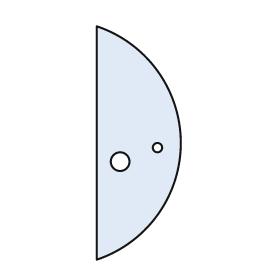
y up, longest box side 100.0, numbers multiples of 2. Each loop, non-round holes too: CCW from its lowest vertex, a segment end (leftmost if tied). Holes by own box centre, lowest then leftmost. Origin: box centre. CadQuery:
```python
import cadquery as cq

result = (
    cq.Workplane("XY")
    .moveTo(-18.0, -50.0)
    .threePointArc((18.0, 0.0), (-18.0, 50.0))
    .close()
    .moveTo(-8.0, -8.0)
    .circle(4.0)
    .moveTo(8.0, -2.0)
    .circle(2.0)
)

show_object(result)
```